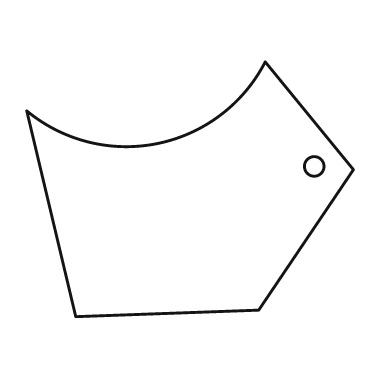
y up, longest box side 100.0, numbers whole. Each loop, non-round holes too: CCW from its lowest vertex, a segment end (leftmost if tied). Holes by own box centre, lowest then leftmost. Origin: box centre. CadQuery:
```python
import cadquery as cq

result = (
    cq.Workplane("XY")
    .moveTo(-35.0, -39.0)
    .lineTo(21.0, -37.0)
    .lineTo(50.0, 6.0)
    .lineTo(23.0, 39.0)
    .threePointArc((-10.0, 14.0), (-50.0, 24.0))
    .close()
    .moveTo(38.0, 7.0)
    .circle(3.0)
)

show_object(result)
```